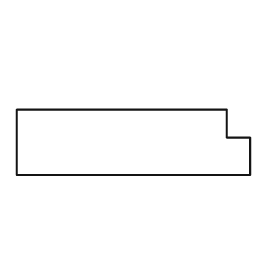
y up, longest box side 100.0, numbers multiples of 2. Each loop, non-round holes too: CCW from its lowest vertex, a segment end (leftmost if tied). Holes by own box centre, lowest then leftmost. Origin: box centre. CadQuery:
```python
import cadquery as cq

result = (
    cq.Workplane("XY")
    .moveTo(-50.0, -14.0)
    .lineTo(50.0, -14.0)
    .lineTo(50.0, 2.0)
    .lineTo(40.0, 2.0)
    .lineTo(40.0, 14.0)
    .lineTo(-50.0, 14.0)
    .close()
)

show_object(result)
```